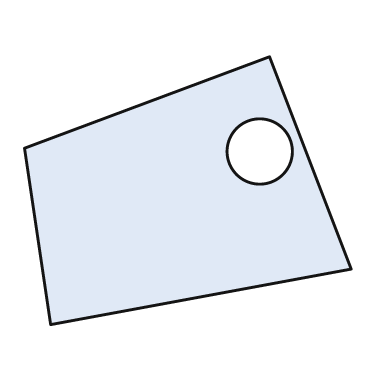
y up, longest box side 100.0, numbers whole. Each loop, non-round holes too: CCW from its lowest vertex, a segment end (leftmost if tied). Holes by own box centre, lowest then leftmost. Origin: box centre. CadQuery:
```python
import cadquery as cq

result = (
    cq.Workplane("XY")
    .moveTo(-42.0, -41.0)
    .lineTo(50.0, -24.0)
    .lineTo(25.0, 41.0)
    .lineTo(-50.0, 13.0)
    .close()
    .moveTo(22.0, 12.0)
    .circle(10.0)
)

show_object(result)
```